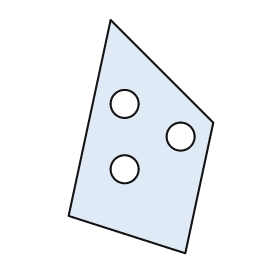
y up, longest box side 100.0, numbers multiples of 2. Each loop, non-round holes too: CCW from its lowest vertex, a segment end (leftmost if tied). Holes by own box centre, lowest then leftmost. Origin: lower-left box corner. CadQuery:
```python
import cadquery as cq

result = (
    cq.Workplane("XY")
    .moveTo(50.0, 0.0)
    .lineTo(62.0, 56.0)
    .lineTo(18.0, 100.0)
    .lineTo(0.0, 16.0)
    .close()
    .moveTo(24.0, 36.0)
    .circle(6.0)
    .moveTo(48.0, 50.0)
    .circle(6.0)
    .moveTo(24.0, 64.0)
    .circle(6.0)
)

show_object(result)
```